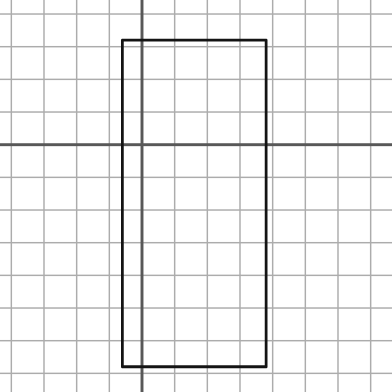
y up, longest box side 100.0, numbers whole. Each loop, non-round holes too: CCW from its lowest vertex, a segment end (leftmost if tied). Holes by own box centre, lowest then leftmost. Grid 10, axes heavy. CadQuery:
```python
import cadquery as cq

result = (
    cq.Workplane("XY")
    .moveTo(-6.0, -68.0)
    .lineTo(38.0, -68.0)
    .lineTo(38.0, 32.0)
    .lineTo(-6.0, 32.0)
    .close()
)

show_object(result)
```